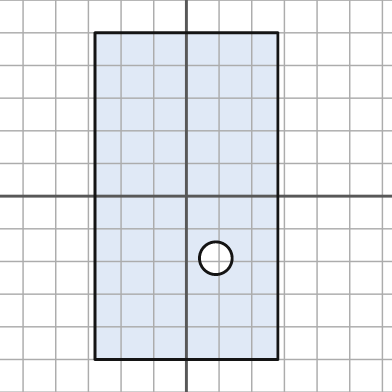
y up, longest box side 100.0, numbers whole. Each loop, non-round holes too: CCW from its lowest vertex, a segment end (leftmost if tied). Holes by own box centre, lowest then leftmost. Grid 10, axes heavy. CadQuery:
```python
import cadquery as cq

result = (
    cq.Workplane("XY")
    .moveTo(-28.0, -50.0)
    .lineTo(28.0, -50.0)
    .lineTo(28.0, 50.0)
    .lineTo(-28.0, 50.0)
    .close()
    .moveTo(9.0, -19.0)
    .circle(5.0)
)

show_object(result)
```